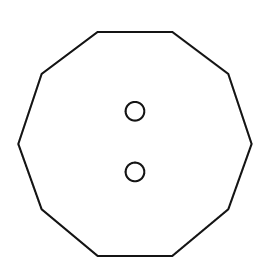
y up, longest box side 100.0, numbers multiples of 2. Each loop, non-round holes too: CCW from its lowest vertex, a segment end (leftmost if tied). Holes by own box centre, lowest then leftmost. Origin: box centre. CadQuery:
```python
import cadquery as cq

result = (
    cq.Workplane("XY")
    .moveTo(-16.0, -48.0)
    .lineTo(16.0, -48.0)
    .lineTo(40.0, -28.0)
    .lineTo(50.0, 0.0)
    .lineTo(40.0, 30.0)
    .lineTo(16.0, 48.0)
    .lineTo(-16.0, 48.0)
    .lineTo(-40.0, 30.0)
    .lineTo(-50.0, 0.0)
    .lineTo(-40.0, -28.0)
    .close()
    .moveTo(0.0, -12.0)
    .circle(4.0)
    .moveTo(0.0, 14.0)
    .circle(4.0)
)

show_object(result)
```